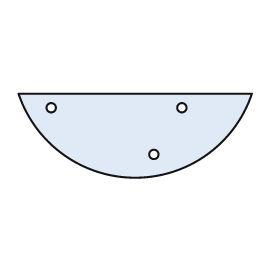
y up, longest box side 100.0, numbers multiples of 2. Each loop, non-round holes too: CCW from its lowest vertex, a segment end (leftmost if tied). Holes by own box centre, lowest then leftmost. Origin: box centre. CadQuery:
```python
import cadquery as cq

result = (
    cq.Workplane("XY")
    .moveTo(-50.0, 18.0)
    .threePointArc((0.0, -18.0), (50.0, 18.0))
    .close()
    .moveTo(8.0, -8.0)
    .circle(2.0)
    .moveTo(-36.0, 12.0)
    .circle(2.0)
    .moveTo(20.0, 12.0)
    .circle(2.0)
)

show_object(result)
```